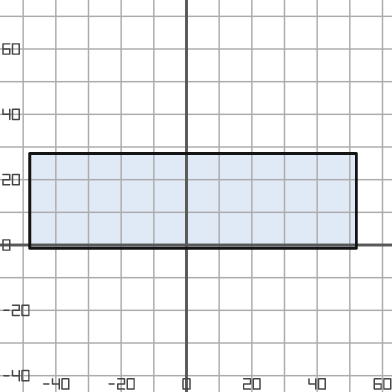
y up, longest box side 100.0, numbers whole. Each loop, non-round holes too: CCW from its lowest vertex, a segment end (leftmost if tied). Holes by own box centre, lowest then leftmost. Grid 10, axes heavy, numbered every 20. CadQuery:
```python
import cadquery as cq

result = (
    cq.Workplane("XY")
    .moveTo(-48.0, -1.0)
    .lineTo(52.0, -1.0)
    .lineTo(52.0, 28.0)
    .lineTo(-48.0, 28.0)
    .close()
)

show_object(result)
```